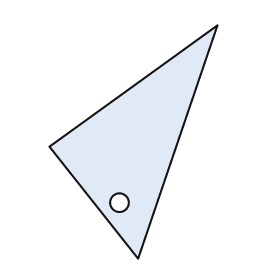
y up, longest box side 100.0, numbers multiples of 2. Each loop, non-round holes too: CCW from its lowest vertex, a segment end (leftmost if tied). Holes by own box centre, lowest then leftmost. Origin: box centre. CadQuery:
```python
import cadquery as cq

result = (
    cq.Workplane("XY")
    .moveTo(2.0, -50.0)
    .lineTo(36.0, 50.0)
    .lineTo(-36.0, -2.0)
    .close()
    .moveTo(-6.0, -26.0)
    .circle(4.0)
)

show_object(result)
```